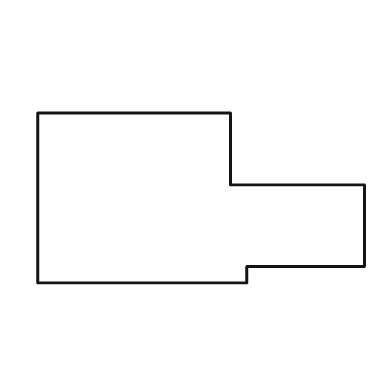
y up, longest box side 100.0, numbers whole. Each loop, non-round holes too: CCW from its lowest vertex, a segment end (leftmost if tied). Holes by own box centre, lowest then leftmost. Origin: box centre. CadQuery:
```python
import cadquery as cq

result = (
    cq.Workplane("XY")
    .moveTo(-50.0, -26.0)
    .lineTo(14.0, -26.0)
    .lineTo(14.0, -21.0)
    .lineTo(50.0, -21.0)
    .lineTo(50.0, 4.0)
    .lineTo(9.0, 4.0)
    .lineTo(9.0, 26.0)
    .lineTo(-50.0, 26.0)
    .close()
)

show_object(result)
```